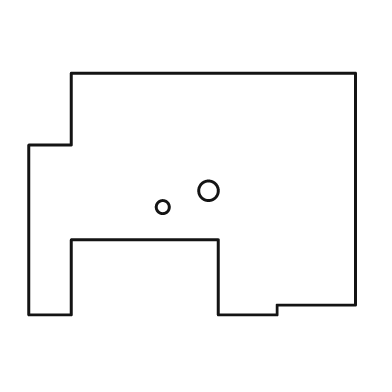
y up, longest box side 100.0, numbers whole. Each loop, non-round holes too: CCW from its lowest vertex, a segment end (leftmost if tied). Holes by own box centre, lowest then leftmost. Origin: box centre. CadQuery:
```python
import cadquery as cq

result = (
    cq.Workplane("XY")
    .moveTo(-50.0, -37.0)
    .lineTo(-37.0, -37.0)
    .lineTo(-37.0, -14.0)
    .lineTo(8.0, -14.0)
    .lineTo(8.0, -37.0)
    .lineTo(26.0, -37.0)
    .lineTo(26.0, -34.0)
    .lineTo(50.0, -34.0)
    .lineTo(50.0, 37.0)
    .lineTo(-37.0, 37.0)
    .lineTo(-37.0, 15.0)
    .lineTo(-50.0, 15.0)
    .close()
    .moveTo(-9.0, -4.0)
    .circle(2.0)
    .moveTo(5.0, 1.0)
    .circle(3.0)
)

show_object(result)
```